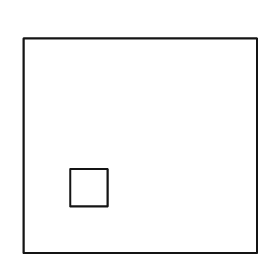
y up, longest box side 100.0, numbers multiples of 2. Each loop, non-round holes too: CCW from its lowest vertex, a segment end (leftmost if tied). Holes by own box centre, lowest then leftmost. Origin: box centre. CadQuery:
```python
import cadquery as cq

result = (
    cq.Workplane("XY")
    .moveTo(-50.0, -46.0)
    .lineTo(50.0, -46.0)
    .lineTo(50.0, 46.0)
    .lineTo(-50.0, 46.0)
    .close()
    .moveTo(-30.0, -26.0)
    .lineTo(-14.0, -26.0)
    .lineTo(-14.0, -10.0)
    .lineTo(-30.0, -10.0)
    .close()
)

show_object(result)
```